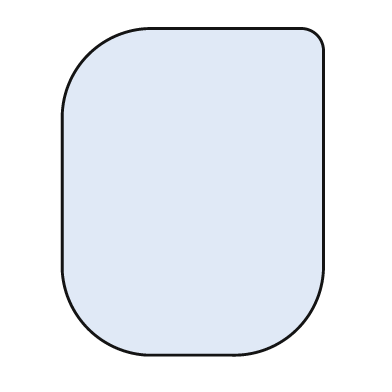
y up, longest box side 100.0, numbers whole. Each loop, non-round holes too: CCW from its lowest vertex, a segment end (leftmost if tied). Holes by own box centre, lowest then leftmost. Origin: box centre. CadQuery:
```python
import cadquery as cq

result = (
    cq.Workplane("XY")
    .moveTo(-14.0, -50.0)
    .lineTo(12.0, -50.0)
    .threePointArc((32.0, -42.0), (40.0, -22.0))
    .lineTo(40.0, 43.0)
    .threePointArc((38.0, 48.0), (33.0, 50.0))
    .lineTo(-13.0, 50.0)
    .threePointArc((-32.0, 42.0), (-40.0, 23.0))
    .lineTo(-40.0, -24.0)
    .threePointArc((-32.0, -42.0), (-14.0, -50.0))
    .close()
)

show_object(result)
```